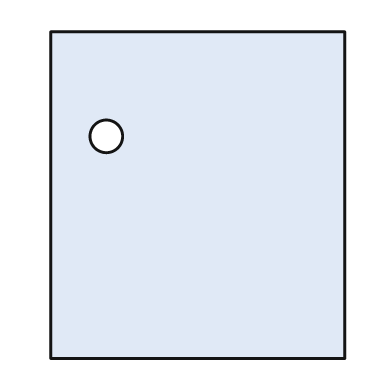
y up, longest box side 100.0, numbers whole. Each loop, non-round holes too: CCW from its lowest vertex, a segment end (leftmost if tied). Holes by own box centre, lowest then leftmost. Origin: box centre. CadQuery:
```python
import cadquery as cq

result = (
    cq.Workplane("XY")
    .moveTo(-45.0, -50.0)
    .lineTo(45.0, -50.0)
    .lineTo(45.0, 50.0)
    .lineTo(-45.0, 50.0)
    .close()
    .moveTo(-28.0, 18.0)
    .circle(5.0)
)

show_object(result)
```